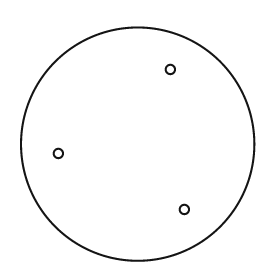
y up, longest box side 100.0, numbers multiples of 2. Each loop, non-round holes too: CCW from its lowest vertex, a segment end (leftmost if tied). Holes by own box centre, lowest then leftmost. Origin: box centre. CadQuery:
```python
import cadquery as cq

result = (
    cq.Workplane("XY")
    .moveTo(0.0, 0.0)
    .circle(50.0)
    .moveTo(20.0, -28.0)
    .circle(2.0)
    .moveTo(-34.0, -4.0)
    .circle(2.0)
    .moveTo(14.0, 32.0)
    .circle(2.0)
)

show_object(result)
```